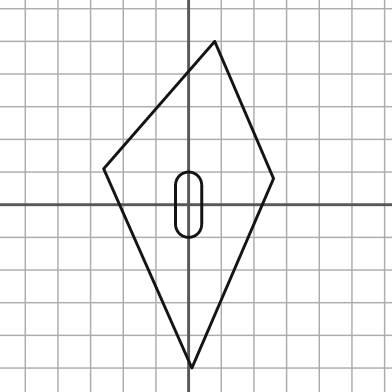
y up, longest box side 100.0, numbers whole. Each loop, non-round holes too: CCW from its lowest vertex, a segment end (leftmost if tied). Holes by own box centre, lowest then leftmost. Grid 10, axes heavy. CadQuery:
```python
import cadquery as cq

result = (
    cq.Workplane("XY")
    .moveTo(1.0, -50.0)
    .lineTo(26.0, 8.0)
    .lineTo(8.0, 50.0)
    .lineTo(-26.0, 11.0)
    .close()
    .moveTo(-4.0, -6.0)
    .threePointArc((0.0, -10.0), (4.0, -6.0))
    .lineTo(4.0, 6.0)
    .threePointArc((0.0, 10.0), (-4.0, 6.0))
    .close()
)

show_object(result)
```